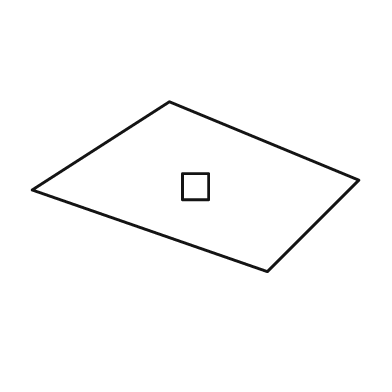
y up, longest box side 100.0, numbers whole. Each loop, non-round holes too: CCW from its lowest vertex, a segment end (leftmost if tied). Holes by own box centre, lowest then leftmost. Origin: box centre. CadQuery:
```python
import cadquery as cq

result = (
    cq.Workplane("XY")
    .moveTo(22.0, -26.0)
    .lineTo(50.0, 2.0)
    .lineTo(-8.0, 26.0)
    .lineTo(-50.0, -1.0)
    .close()
    .moveTo(-4.0, -4.0)
    .lineTo(4.0, -4.0)
    .lineTo(4.0, 4.0)
    .lineTo(-4.0, 4.0)
    .close()
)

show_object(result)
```